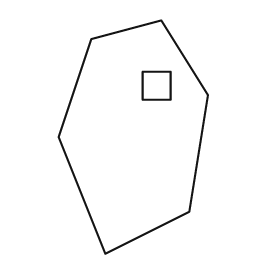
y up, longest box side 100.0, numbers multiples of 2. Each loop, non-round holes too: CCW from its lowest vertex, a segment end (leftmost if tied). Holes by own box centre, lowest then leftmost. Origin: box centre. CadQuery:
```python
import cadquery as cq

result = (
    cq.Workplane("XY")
    .moveTo(-12.0, -50.0)
    .lineTo(24.0, -32.0)
    .lineTo(32.0, 18.0)
    .lineTo(12.0, 50.0)
    .lineTo(-18.0, 42.0)
    .lineTo(-32.0, 0.0)
    .close()
    .moveTo(4.0, 16.0)
    .lineTo(16.0, 16.0)
    .lineTo(16.0, 28.0)
    .lineTo(4.0, 28.0)
    .close()
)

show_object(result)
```